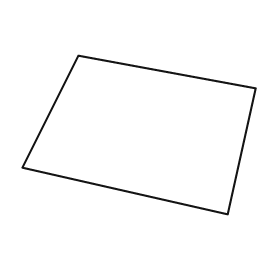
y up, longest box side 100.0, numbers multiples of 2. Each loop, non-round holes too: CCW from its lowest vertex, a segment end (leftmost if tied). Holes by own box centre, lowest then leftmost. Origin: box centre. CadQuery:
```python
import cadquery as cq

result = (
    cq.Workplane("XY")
    .moveTo(38.0, -34.0)
    .lineTo(50.0, 20.0)
    .lineTo(-26.0, 34.0)
    .lineTo(-50.0, -14.0)
    .close()
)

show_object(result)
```